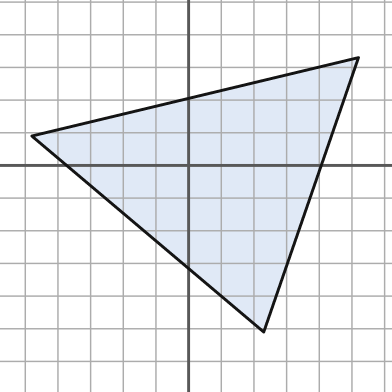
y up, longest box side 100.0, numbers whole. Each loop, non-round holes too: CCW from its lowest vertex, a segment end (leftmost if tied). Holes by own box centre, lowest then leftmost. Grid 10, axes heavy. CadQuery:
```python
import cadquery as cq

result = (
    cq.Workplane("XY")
    .moveTo(23.0, -51.0)
    .lineTo(52.0, 33.0)
    .lineTo(-48.0, 9.0)
    .close()
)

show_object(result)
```